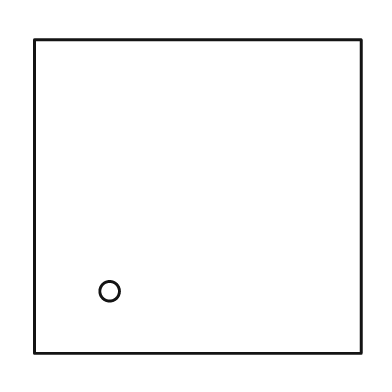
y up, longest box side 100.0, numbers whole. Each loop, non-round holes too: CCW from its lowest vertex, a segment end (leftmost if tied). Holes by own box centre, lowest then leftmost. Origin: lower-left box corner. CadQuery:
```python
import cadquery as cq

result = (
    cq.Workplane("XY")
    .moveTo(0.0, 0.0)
    .lineTo(100.0, 0.0)
    .lineTo(100.0, 96.0)
    .lineTo(0.0, 96.0)
    .close()
    .moveTo(23.0, 19.0)
    .circle(3.0)
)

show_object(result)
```